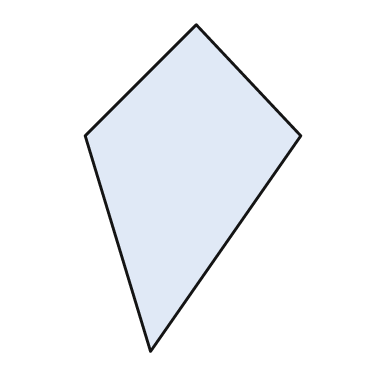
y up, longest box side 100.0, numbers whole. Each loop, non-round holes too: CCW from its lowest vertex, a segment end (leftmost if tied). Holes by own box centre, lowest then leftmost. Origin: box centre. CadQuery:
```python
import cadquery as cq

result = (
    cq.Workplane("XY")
    .moveTo(-13.0, -50.0)
    .lineTo(33.0, 16.0)
    .lineTo(1.0, 50.0)
    .lineTo(-33.0, 16.0)
    .close()
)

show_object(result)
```